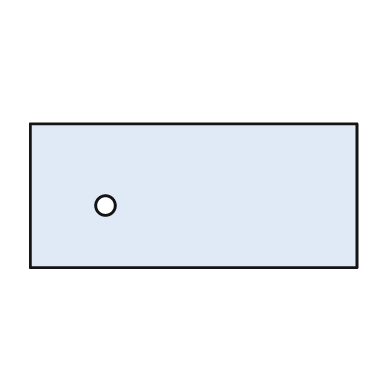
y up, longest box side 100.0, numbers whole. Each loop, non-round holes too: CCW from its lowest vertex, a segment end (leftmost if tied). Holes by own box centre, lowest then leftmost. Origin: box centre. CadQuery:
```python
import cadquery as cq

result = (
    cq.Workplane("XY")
    .moveTo(-50.0, -22.0)
    .lineTo(50.0, -22.0)
    .lineTo(50.0, 22.0)
    .lineTo(-50.0, 22.0)
    .close()
    .moveTo(-27.0, -3.0)
    .circle(3.0)
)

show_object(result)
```